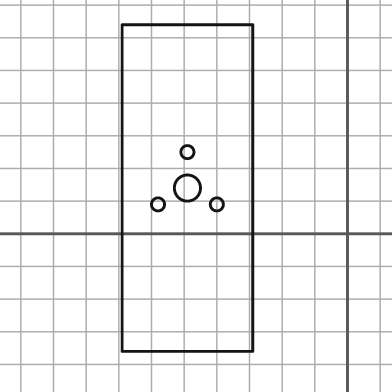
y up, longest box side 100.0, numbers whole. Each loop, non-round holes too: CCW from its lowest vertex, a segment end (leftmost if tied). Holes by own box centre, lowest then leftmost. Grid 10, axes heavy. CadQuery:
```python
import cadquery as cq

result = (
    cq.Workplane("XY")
    .moveTo(-69.0, -36.0)
    .lineTo(-29.0, -36.0)
    .lineTo(-29.0, 64.0)
    .lineTo(-69.0, 64.0)
    .close()
    .moveTo(-58.0, 9.0)
    .circle(2.0)
    .moveTo(-40.0, 9.0)
    .circle(2.0)
    .moveTo(-49.0, 14.0)
    .circle(4.0)
    .moveTo(-49.0, 25.0)
    .circle(2.0)
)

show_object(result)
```